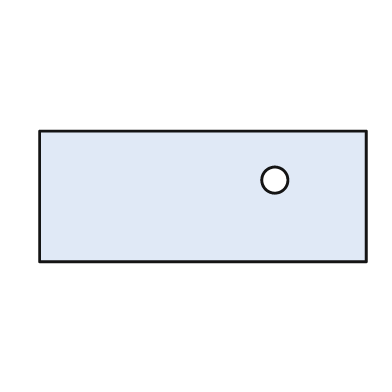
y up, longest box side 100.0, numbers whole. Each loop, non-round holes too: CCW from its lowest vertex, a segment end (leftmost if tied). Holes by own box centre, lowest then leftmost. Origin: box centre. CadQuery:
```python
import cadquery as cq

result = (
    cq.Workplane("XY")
    .moveTo(-50.0, -20.0)
    .lineTo(50.0, -20.0)
    .lineTo(50.0, 20.0)
    .lineTo(-50.0, 20.0)
    .close()
    .moveTo(22.0, 5.0)
    .circle(4.0)
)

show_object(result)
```